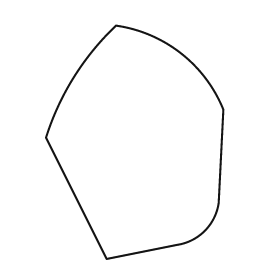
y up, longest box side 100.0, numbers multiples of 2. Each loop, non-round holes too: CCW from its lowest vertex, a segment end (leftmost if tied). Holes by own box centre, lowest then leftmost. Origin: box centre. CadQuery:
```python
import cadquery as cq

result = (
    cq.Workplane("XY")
    .moveTo(-12.0, -50.0)
    .lineTo(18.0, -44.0)
    .threePointArc((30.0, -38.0), (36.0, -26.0))
    .lineTo(38.0, 14.0)
    .threePointArc((20.0, 38.0), (-8.0, 50.0))
    .threePointArc((-26.0, 28.0), (-38.0, 2.0))
    .close()
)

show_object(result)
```